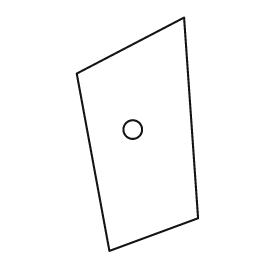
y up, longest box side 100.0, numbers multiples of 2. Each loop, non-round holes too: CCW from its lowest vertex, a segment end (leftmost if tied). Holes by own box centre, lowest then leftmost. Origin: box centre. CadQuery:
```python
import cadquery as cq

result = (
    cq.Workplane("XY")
    .moveTo(-12.0, -50.0)
    .lineTo(26.0, -36.0)
    .lineTo(20.0, 50.0)
    .lineTo(-26.0, 26.0)
    .close()
    .moveTo(-2.0, 2.0)
    .circle(4.0)
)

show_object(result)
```